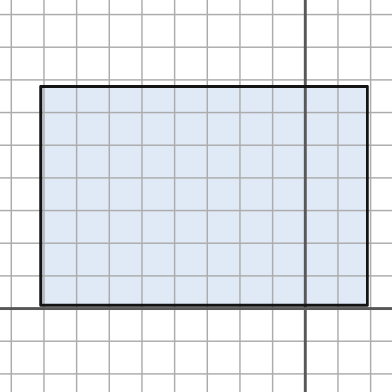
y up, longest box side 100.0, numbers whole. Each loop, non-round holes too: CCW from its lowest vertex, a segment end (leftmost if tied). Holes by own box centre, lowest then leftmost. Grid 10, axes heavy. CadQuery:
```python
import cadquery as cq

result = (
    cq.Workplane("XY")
    .moveTo(-81.0, 1.0)
    .lineTo(19.0, 1.0)
    .lineTo(19.0, 68.0)
    .lineTo(-81.0, 68.0)
    .close()
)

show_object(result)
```